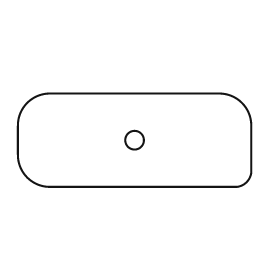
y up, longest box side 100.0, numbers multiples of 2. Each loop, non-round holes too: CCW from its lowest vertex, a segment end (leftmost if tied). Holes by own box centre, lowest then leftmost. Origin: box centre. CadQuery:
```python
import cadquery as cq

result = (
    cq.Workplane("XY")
    .moveTo(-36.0, -20.0)
    .lineTo(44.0, -20.0)
    .threePointArc((48.0, -18.0), (50.0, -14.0))
    .lineTo(50.0, 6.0)
    .threePointArc((46.0, 16.0), (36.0, 20.0))
    .lineTo(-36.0, 20.0)
    .threePointArc((-46.0, 16.0), (-50.0, 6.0))
    .lineTo(-50.0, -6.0)
    .threePointArc((-46.0, -16.0), (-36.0, -20.0))
    .close()
    .moveTo(0.0, 0.0)
    .circle(4.0)
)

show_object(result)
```